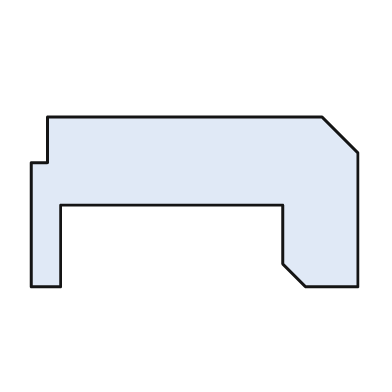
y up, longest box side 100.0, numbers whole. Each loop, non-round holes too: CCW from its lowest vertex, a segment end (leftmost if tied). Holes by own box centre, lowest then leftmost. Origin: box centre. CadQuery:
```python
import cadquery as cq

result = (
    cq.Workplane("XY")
    .moveTo(-50.0, -26.0)
    .lineTo(-41.0, -26.0)
    .lineTo(-41.0, -1.0)
    .lineTo(27.0, -1.0)
    .lineTo(27.0, -19.0)
    .lineTo(34.0, -26.0)
    .lineTo(50.0, -26.0)
    .lineTo(50.0, 15.0)
    .lineTo(39.0, 26.0)
    .lineTo(-45.0, 26.0)
    .lineTo(-45.0, 12.0)
    .lineTo(-50.0, 12.0)
    .close()
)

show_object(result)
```